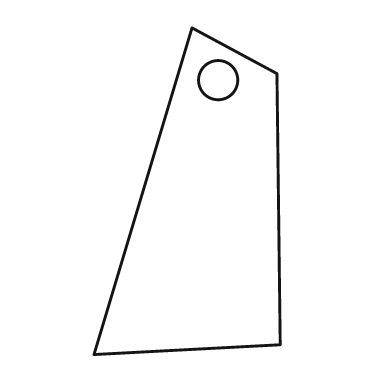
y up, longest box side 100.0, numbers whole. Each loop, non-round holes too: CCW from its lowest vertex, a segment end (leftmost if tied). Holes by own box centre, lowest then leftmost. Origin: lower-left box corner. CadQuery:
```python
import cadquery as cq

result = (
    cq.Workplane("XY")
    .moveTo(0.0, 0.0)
    .lineTo(57.0, 3.0)
    .lineTo(56.0, 86.0)
    .lineTo(30.0, 100.0)
    .close()
    .moveTo(38.0, 84.0)
    .circle(6.0)
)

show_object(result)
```